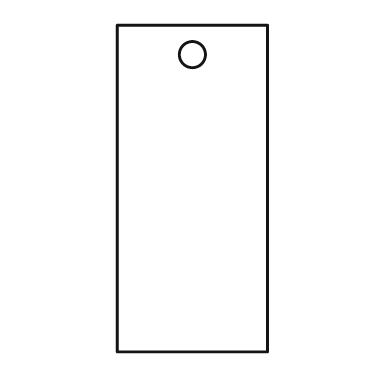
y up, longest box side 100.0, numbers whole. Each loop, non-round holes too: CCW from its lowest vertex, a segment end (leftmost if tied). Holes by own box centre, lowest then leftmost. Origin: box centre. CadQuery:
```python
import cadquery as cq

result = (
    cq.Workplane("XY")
    .moveTo(-23.0, -50.0)
    .lineTo(23.0, -50.0)
    .lineTo(23.0, 50.0)
    .lineTo(-23.0, 50.0)
    .close()
    .moveTo(0.0, 41.0)
    .circle(4.0)
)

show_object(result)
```